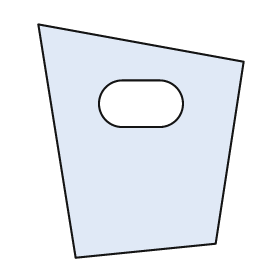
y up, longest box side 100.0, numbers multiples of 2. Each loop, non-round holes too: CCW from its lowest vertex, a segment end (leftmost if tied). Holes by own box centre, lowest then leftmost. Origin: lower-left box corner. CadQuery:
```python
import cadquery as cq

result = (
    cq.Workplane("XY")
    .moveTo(16.0, 0.0)
    .lineTo(76.0, 6.0)
    .lineTo(88.0, 84.0)
    .lineTo(0.0, 100.0)
    .close()
    .moveTo(36.0, 56.0)
    .lineTo(52.0, 56.0)
    .threePointArc((62.0, 66.0), (52.0, 76.0))
    .lineTo(36.0, 76.0)
    .threePointArc((26.0, 66.0), (36.0, 56.0))
    .close()
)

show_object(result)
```